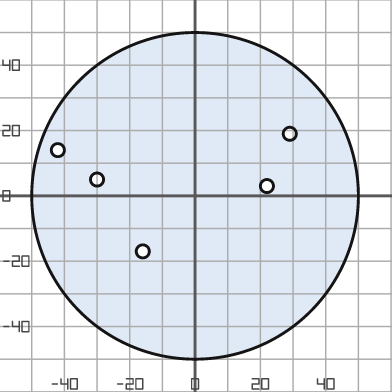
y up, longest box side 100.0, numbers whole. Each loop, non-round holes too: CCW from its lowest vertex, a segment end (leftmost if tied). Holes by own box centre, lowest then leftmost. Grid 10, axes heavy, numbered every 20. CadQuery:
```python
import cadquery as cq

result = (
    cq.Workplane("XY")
    .moveTo(0.0, 0.0)
    .circle(50.0)
    .moveTo(-16.0, -17.0)
    .circle(2.0)
    .moveTo(22.0, 3.0)
    .circle(2.0)
    .moveTo(-30.0, 5.0)
    .circle(2.0)
    .moveTo(-42.0, 14.0)
    .circle(2.0)
    .moveTo(29.0, 19.0)
    .circle(2.0)
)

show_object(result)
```